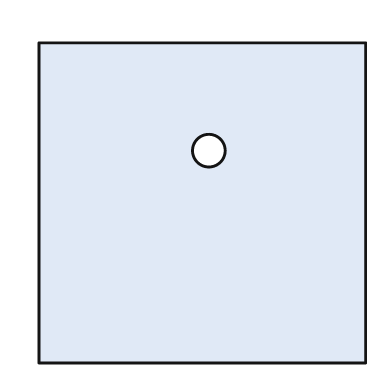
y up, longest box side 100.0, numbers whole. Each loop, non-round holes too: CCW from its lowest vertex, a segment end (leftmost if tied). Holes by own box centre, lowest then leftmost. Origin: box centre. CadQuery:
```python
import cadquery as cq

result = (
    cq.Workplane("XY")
    .moveTo(-50.0, -49.0)
    .lineTo(50.0, -49.0)
    .lineTo(50.0, 49.0)
    .lineTo(-50.0, 49.0)
    .close()
    .moveTo(2.0, 16.0)
    .circle(5.0)
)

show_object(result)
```